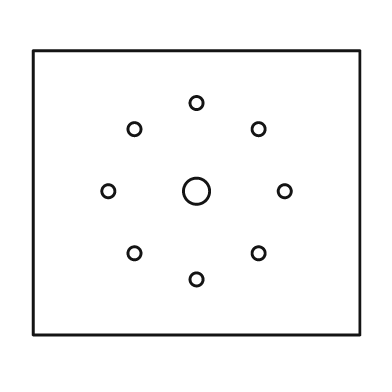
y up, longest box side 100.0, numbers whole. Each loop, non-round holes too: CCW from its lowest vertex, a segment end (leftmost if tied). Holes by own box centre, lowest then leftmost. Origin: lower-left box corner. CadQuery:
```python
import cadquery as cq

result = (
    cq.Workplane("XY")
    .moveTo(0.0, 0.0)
    .lineTo(100.0, 0.0)
    .lineTo(100.0, 87.0)
    .lineTo(0.0, 87.0)
    .close()
    .moveTo(50.0, 17.0)
    .circle(2.0)
    .moveTo(31.0, 25.0)
    .circle(2.0)
    .moveTo(69.0, 25.0)
    .circle(2.0)
    .moveTo(23.0, 44.0)
    .circle(2.0)
    .moveTo(50.0, 44.0)
    .circle(4.0)
    .moveTo(77.0, 44.0)
    .circle(2.0)
    .moveTo(31.0, 63.0)
    .circle(2.0)
    .moveTo(69.0, 63.0)
    .circle(2.0)
    .moveTo(50.0, 71.0)
    .circle(2.0)
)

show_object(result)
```